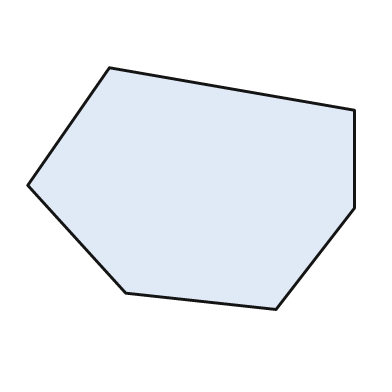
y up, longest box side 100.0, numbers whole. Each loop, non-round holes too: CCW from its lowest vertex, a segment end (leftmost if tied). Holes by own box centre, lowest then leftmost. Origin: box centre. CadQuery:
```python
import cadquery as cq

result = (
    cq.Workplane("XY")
    .moveTo(26.0, -37.0)
    .lineTo(50.0, -6.0)
    .lineTo(50.0, 24.0)
    .lineTo(-25.0, 37.0)
    .lineTo(-50.0, 1.0)
    .lineTo(-20.0, -32.0)
    .close()
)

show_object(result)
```